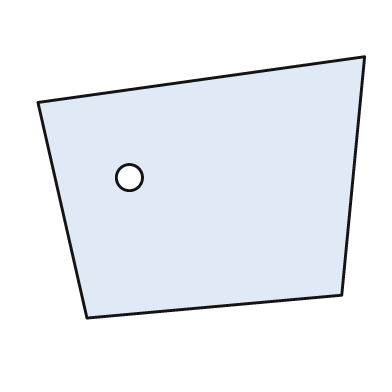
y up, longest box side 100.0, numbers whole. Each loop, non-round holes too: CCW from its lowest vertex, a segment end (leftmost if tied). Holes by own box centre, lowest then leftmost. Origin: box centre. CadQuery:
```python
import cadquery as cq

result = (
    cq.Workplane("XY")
    .moveTo(-35.0, -40.0)
    .lineTo(43.0, -33.0)
    .lineTo(50.0, 40.0)
    .lineTo(-50.0, 26.0)
    .close()
    .moveTo(-22.0, 3.0)
    .circle(4.0)
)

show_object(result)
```